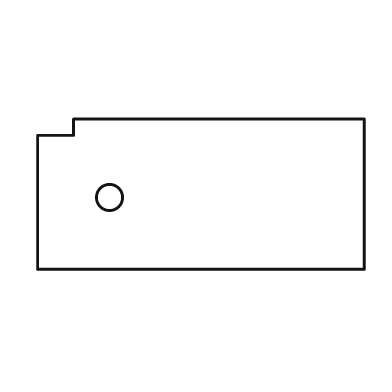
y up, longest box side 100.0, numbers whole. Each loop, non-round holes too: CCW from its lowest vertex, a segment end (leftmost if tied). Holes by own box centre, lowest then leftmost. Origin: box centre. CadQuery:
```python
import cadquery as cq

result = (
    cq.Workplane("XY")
    .moveTo(-50.0, -23.0)
    .lineTo(50.0, -23.0)
    .lineTo(50.0, 23.0)
    .lineTo(-39.0, 23.0)
    .lineTo(-39.0, 18.0)
    .lineTo(-50.0, 18.0)
    .close()
    .moveTo(-28.0, -1.0)
    .circle(4.0)
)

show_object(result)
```